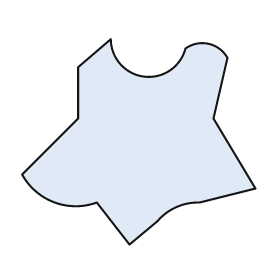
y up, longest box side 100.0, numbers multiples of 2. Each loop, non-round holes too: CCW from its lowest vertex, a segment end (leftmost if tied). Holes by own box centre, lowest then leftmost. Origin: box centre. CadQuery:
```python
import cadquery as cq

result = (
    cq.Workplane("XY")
    .moveTo(-4.0, -44.0)
    .lineTo(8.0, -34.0)
    .threePointArc((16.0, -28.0), (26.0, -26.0))
    .lineTo(50.0, -20.0)
    .lineTo(32.0, 10.0)
    .lineTo(38.0, 36.0)
    .threePointArc((30.0, 42.0), (20.0, 40.0))
    .threePointArc((2.0, 28.0), (-12.0, 44.0))
    .lineTo(-26.0, 32.0)
    .lineTo(-26.0, 10.0)
    .lineTo(-50.0, -14.0)
    .threePointArc((-36.0, -26.0), (-18.0, -26.0))
    .close()
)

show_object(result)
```